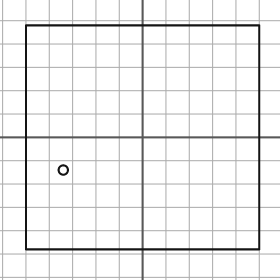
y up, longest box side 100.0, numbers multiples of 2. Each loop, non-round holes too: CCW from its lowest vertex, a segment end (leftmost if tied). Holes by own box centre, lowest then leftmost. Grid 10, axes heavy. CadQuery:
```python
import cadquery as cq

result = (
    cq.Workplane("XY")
    .moveTo(-50.0, -48.0)
    .lineTo(50.0, -48.0)
    .lineTo(50.0, 48.0)
    .lineTo(-50.0, 48.0)
    .close()
    .moveTo(-34.0, -14.0)
    .circle(2.0)
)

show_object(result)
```